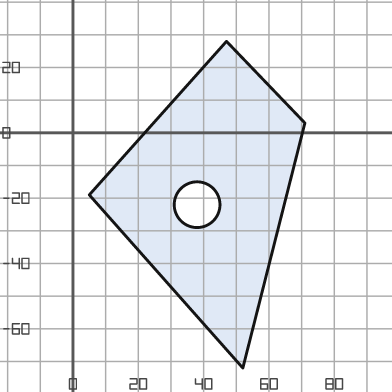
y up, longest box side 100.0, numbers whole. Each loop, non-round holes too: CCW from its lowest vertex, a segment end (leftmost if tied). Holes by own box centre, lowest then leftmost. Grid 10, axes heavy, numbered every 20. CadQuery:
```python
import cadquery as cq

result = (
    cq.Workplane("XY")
    .moveTo(52.0, -72.0)
    .lineTo(71.0, 3.0)
    .lineTo(47.0, 28.0)
    .lineTo(5.0, -19.0)
    .close()
    .moveTo(38.0, -22.0)
    .circle(7.0)
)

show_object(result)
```